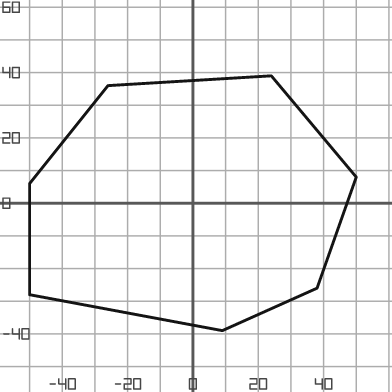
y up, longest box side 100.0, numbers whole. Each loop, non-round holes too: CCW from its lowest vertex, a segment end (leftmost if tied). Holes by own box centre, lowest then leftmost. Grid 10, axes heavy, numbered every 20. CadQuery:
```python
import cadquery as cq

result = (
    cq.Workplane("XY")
    .moveTo(9.0, -39.0)
    .lineTo(38.0, -26.0)
    .lineTo(50.0, 8.0)
    .lineTo(24.0, 39.0)
    .lineTo(-26.0, 36.0)
    .lineTo(-50.0, 6.0)
    .lineTo(-50.0, -28.0)
    .close()
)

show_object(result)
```